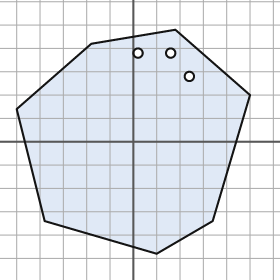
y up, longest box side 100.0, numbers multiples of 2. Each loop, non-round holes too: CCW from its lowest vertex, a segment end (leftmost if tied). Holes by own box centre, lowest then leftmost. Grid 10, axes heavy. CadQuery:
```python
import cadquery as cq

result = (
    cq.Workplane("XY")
    .moveTo(10.0, -48.0)
    .lineTo(34.0, -34.0)
    .lineTo(50.0, 20.0)
    .lineTo(18.0, 48.0)
    .lineTo(-18.0, 42.0)
    .lineTo(-50.0, 14.0)
    .lineTo(-38.0, -34.0)
    .close()
    .moveTo(24.0, 28.0)
    .circle(2.0)
    .moveTo(2.0, 38.0)
    .circle(2.0)
    .moveTo(16.0, 38.0)
    .circle(2.0)
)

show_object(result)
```